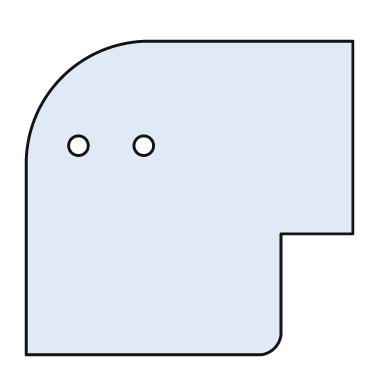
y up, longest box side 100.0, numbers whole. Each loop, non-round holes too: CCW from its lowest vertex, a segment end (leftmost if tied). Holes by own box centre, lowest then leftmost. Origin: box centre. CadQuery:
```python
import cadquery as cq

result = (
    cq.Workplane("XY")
    .moveTo(-50.0, -48.0)
    .lineTo(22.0, -48.0)
    .threePointArc((26.0, -46.0), (28.0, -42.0))
    .lineTo(28.0, -11.0)
    .lineTo(50.0, -11.0)
    .lineTo(50.0, 48.0)
    .lineTo(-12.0, 48.0)
    .threePointArc((-39.0, 37.0), (-50.0, 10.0))
    .close()
    .moveTo(-34.0, 16.0)
    .circle(3.0)
    .moveTo(-14.0, 16.0)
    .circle(3.0)
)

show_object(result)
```